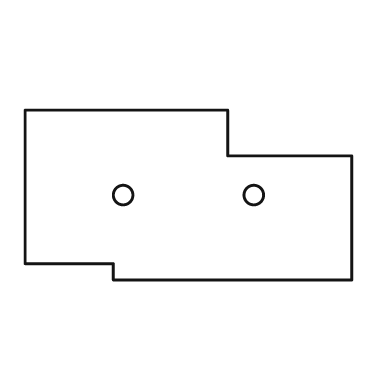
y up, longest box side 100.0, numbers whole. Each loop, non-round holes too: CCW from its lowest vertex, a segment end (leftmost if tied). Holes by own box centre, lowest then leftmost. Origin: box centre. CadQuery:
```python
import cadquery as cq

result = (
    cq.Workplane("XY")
    .moveTo(-23.0, -26.0)
    .lineTo(50.0, -26.0)
    .lineTo(50.0, 12.0)
    .lineTo(12.0, 12.0)
    .lineTo(12.0, 26.0)
    .lineTo(-50.0, 26.0)
    .lineTo(-50.0, -21.0)
    .lineTo(-23.0, -21.0)
    .close()
    .moveTo(-20.0, 0.0)
    .circle(3.0)
    .moveTo(20.0, 0.0)
    .circle(3.0)
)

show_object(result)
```